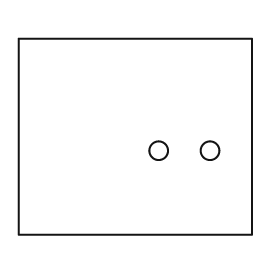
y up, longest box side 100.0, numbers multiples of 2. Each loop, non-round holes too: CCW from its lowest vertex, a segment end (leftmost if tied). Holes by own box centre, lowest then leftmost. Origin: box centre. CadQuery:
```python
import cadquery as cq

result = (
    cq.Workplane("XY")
    .moveTo(-50.0, -42.0)
    .lineTo(50.0, -42.0)
    .lineTo(50.0, 42.0)
    .lineTo(-50.0, 42.0)
    .close()
    .moveTo(10.0, -6.0)
    .circle(4.0)
    .moveTo(32.0, -6.0)
    .circle(4.0)
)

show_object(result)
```